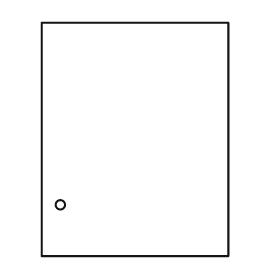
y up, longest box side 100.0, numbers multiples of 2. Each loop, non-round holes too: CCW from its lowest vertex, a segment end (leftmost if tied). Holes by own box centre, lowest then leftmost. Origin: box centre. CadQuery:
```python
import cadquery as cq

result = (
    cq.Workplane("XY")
    .moveTo(-40.0, -50.0)
    .lineTo(40.0, -50.0)
    .lineTo(40.0, 50.0)
    .lineTo(-40.0, 50.0)
    .close()
    .moveTo(-32.0, -28.0)
    .circle(2.0)
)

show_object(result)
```